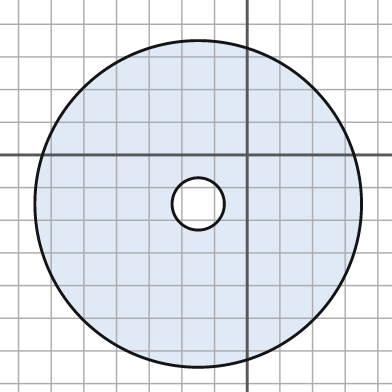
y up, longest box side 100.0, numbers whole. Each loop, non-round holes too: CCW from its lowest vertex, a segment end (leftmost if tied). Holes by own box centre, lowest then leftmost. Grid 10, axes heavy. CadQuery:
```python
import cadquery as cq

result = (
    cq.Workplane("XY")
    .moveTo(-15.0, -15.0)
    .circle(50.0)
    .moveTo(-15.0, -15.0)
    .circle(8.0)
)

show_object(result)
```